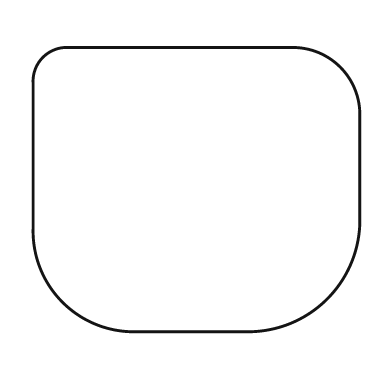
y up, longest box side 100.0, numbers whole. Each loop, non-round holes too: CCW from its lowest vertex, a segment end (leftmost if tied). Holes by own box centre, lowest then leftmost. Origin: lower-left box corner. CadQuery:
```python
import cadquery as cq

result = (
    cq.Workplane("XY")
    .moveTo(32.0, 0.0)
    .lineTo(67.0, 0.0)
    .threePointArc((90.0, 10.0), (100.0, 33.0))
    .lineTo(100.0, 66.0)
    .threePointArc((94.0, 81.0), (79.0, 87.0))
    .lineTo(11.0, 87.0)
    .threePointArc((3.0, 84.0), (0.0, 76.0))
    .lineTo(0.0, 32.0)
    .threePointArc((9.0, 9.0), (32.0, 0.0))
    .close()
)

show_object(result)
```